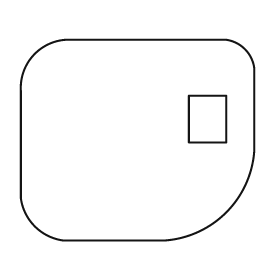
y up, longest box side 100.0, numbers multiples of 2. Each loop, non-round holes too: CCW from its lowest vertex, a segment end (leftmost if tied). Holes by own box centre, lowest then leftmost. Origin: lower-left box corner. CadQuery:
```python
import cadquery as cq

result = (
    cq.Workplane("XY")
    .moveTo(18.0, 0.0)
    .lineTo(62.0, 0.0)
    .threePointArc((88.0, 12.0), (100.0, 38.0))
    .lineTo(100.0, 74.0)
    .threePointArc((96.0, 82.0), (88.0, 86.0))
    .lineTo(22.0, 86.0)
    .threePointArc((6.0, 80.0), (0.0, 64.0))
    .lineTo(0.0, 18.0)
    .threePointArc((6.0, 6.0), (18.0, 0.0))
    .close()
    .moveTo(72.0, 42.0)
    .lineTo(88.0, 42.0)
    .lineTo(88.0, 62.0)
    .lineTo(72.0, 62.0)
    .close()
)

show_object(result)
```